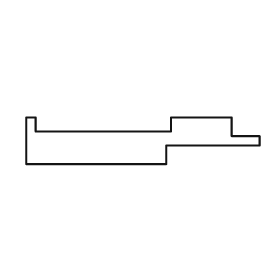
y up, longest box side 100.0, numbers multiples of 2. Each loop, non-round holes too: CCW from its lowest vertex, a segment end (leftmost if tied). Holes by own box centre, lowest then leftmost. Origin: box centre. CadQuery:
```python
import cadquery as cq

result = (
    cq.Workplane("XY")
    .moveTo(-50.0, -10.0)
    .lineTo(10.0, -10.0)
    .lineTo(10.0, -2.0)
    .lineTo(50.0, -2.0)
    .lineTo(50.0, 2.0)
    .lineTo(38.0, 2.0)
    .lineTo(38.0, 10.0)
    .lineTo(12.0, 10.0)
    .lineTo(12.0, 4.0)
    .lineTo(-46.0, 4.0)
    .lineTo(-46.0, 10.0)
    .lineTo(-50.0, 10.0)
    .close()
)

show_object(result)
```